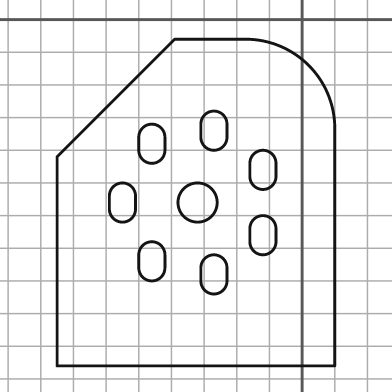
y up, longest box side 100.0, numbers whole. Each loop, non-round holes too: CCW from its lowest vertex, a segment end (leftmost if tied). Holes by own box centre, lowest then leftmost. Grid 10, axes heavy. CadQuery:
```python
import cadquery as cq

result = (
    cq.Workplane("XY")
    .moveTo(-75.0, -106.0)
    .lineTo(10.0, -106.0)
    .lineTo(10.0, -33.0)
    .threePointArc((2.0, -14.0), (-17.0, -6.0))
    .lineTo(-39.0, -6.0)
    .lineTo(-75.0, -42.0)
    .close()
    .moveTo(-31.0, -80.0)
    .threePointArc((-27.0, -84.0), (-23.0, -80.0))
    .lineTo(-23.0, -76.0)
    .threePointArc((-27.0, -72.0), (-31.0, -76.0))
    .close()
    .moveTo(-50.0, -76.0)
    .threePointArc((-46.0, -80.0), (-42.0, -76.0))
    .lineTo(-42.0, -72.0)
    .threePointArc((-46.0, -68.0), (-50.0, -72.0))
    .close()
    .moveTo(-16.0, -68.0)
    .threePointArc((-12.0, -72.0), (-8.0, -68.0))
    .lineTo(-8.0, -64.0)
    .threePointArc((-12.0, -60.0), (-16.0, -64.0))
    .close()
    .moveTo(-59.0, -58.0)
    .threePointArc((-55.0, -62.0), (-51.0, -58.0))
    .lineTo(-51.0, -54.0)
    .threePointArc((-55.0, -50.0), (-59.0, -54.0))
    .close()
    .moveTo(-32.0, -56.0)
    .circle(6.0)
    .moveTo(-16.0, -48.0)
    .threePointArc((-12.0, -52.0), (-8.0, -48.0))
    .lineTo(-8.0, -44.0)
    .threePointArc((-12.0, -40.0), (-16.0, -44.0))
    .close()
    .moveTo(-50.0, -40.0)
    .threePointArc((-46.0, -44.0), (-42.0, -40.0))
    .lineTo(-42.0, -36.0)
    .threePointArc((-46.0, -32.0), (-50.0, -36.0))
    .close()
    .moveTo(-31.0, -36.0)
    .threePointArc((-27.0, -40.0), (-23.0, -36.0))
    .lineTo(-23.0, -32.0)
    .threePointArc((-27.0, -28.0), (-31.0, -32.0))
    .close()
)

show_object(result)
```